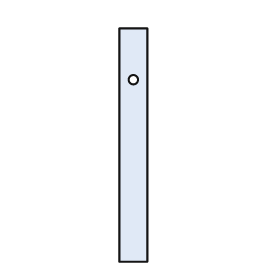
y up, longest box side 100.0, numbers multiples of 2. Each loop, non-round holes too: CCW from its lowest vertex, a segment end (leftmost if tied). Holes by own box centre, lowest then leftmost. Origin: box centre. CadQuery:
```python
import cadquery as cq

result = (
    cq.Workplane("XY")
    .moveTo(-6.0, -50.0)
    .lineTo(6.0, -50.0)
    .lineTo(6.0, 50.0)
    .lineTo(-6.0, 50.0)
    .close()
    .moveTo(0.0, 28.0)
    .circle(2.0)
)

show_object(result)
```